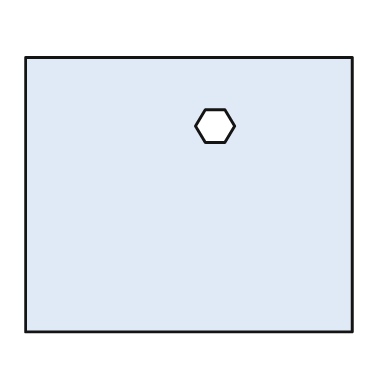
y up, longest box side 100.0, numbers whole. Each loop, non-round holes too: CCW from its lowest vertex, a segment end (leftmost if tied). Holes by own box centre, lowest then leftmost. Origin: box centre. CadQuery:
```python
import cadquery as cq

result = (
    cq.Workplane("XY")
    .moveTo(-50.0, -42.0)
    .lineTo(50.0, -42.0)
    .lineTo(50.0, 42.0)
    .lineTo(-50.0, 42.0)
    .close()
    .moveTo(5.0, 16.0)
    .lineTo(11.0, 16.0)
    .lineTo(14.0, 21.0)
    .lineTo(11.0, 26.0)
    .lineTo(5.0, 26.0)
    .lineTo(2.0, 21.0)
    .close()
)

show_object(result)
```